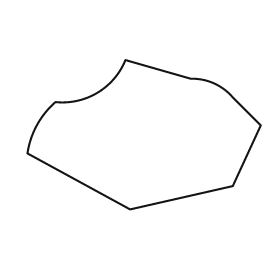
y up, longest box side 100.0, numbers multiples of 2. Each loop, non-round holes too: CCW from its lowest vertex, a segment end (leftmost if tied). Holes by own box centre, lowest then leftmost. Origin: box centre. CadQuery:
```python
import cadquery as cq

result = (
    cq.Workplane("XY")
    .moveTo(-6.0, -32.0)
    .lineTo(38.0, -22.0)
    .lineTo(50.0, 4.0)
    .lineTo(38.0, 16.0)
    .threePointArc((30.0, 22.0), (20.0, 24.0))
    .lineTo(-8.0, 32.0)
    .threePointArc((-20.0, 18.0), (-38.0, 14.0))
    .threePointArc((-46.0, 4.0), (-50.0, -8.0))
    .close()
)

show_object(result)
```